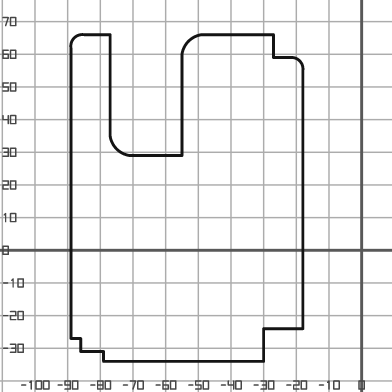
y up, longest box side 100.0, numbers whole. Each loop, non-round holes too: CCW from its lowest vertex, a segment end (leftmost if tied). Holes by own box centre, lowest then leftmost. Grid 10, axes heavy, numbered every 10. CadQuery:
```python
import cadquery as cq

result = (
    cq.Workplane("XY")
    .moveTo(-79.0, -34.0)
    .lineTo(-30.0, -34.0)
    .lineTo(-30.0, -24.0)
    .lineTo(-18.0, -24.0)
    .lineTo(-18.0, 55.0)
    .threePointArc((-19.0, 58.0), (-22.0, 59.0))
    .lineTo(-27.0, 59.0)
    .lineTo(-27.0, 66.0)
    .lineTo(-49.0, 66.0)
    .threePointArc((-53.0, 64.0), (-55.0, 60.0))
    .lineTo(-55.0, 29.0)
    .lineTo(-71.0, 29.0)
    .threePointArc((-75.0, 31.0), (-77.0, 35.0))
    .lineTo(-77.0, 66.0)
    .lineTo(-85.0, 66.0)
    .threePointArc((-88.0, 65.0), (-89.0, 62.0))
    .lineTo(-89.0, -27.0)
    .lineTo(-86.0, -27.0)
    .lineTo(-86.0, -31.0)
    .lineTo(-79.0, -31.0)
    .close()
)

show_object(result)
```